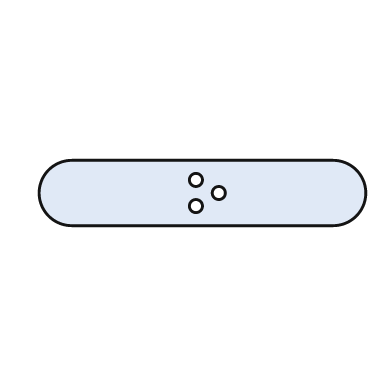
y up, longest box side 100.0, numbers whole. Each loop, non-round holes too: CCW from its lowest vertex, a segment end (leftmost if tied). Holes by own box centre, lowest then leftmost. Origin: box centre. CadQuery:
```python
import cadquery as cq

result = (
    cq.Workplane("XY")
    .moveTo(-40.0, -10.0)
    .lineTo(40.0, -10.0)
    .threePointArc((50.0, 0.0), (40.0, 10.0))
    .lineTo(-40.0, 10.0)
    .threePointArc((-50.0, 0.0), (-40.0, -10.0))
    .close()
    .moveTo(-2.0, -4.0)
    .circle(2.0)
    .moveTo(5.0, 0.0)
    .circle(2.0)
    .moveTo(-2.0, 4.0)
    .circle(2.0)
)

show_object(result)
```